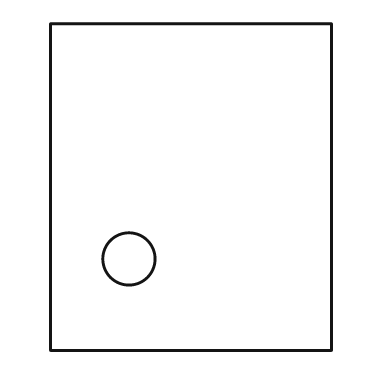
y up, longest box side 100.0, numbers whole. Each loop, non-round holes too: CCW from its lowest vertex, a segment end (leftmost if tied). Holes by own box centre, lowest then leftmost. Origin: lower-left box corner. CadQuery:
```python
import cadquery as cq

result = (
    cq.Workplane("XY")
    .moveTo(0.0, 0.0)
    .lineTo(86.0, 0.0)
    .lineTo(86.0, 100.0)
    .lineTo(0.0, 100.0)
    .close()
    .moveTo(24.0, 28.0)
    .circle(8.0)
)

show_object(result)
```